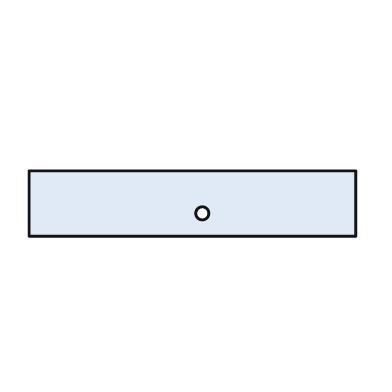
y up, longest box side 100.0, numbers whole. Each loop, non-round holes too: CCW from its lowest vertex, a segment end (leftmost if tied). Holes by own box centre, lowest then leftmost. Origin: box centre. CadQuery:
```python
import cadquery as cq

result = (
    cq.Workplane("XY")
    .moveTo(-50.0, -10.0)
    .lineTo(50.0, -10.0)
    .lineTo(50.0, 10.0)
    .lineTo(-50.0, 10.0)
    .close()
    .moveTo(3.0, -3.0)
    .circle(2.0)
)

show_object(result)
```